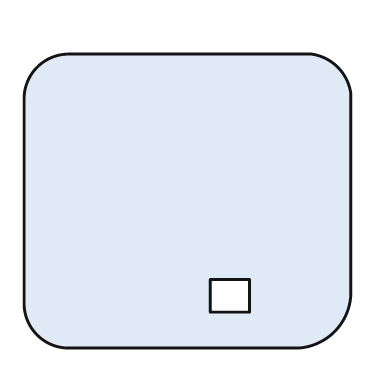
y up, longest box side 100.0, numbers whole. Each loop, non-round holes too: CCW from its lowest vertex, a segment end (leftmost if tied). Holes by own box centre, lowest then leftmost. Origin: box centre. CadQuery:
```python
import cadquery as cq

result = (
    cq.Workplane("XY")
    .moveTo(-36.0, -45.0)
    .lineTo(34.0, -45.0)
    .threePointArc((45.0, -40.0), (50.0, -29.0))
    .lineTo(50.0, 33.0)
    .threePointArc((46.0, 41.0), (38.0, 45.0))
    .lineTo(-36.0, 45.0)
    .threePointArc((-46.0, 41.0), (-50.0, 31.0))
    .lineTo(-50.0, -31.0)
    .threePointArc((-46.0, -41.0), (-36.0, -45.0))
    .close()
    .moveTo(7.0, -34.0)
    .lineTo(19.0, -34.0)
    .lineTo(19.0, -24.0)
    .lineTo(7.0, -24.0)
    .close()
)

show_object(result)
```